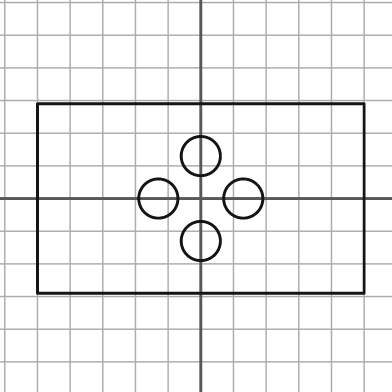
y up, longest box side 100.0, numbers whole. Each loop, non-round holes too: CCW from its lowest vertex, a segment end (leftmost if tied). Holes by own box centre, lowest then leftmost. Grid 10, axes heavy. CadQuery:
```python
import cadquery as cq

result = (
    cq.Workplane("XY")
    .moveTo(-50.0, -29.0)
    .lineTo(50.0, -29.0)
    .lineTo(50.0, 29.0)
    .lineTo(-50.0, 29.0)
    .close()
    .moveTo(0.0, -13.0)
    .circle(6.0)
    .moveTo(-13.0, 0.0)
    .circle(6.0)
    .moveTo(13.0, 0.0)
    .circle(6.0)
    .moveTo(0.0, 13.0)
    .circle(6.0)
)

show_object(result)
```